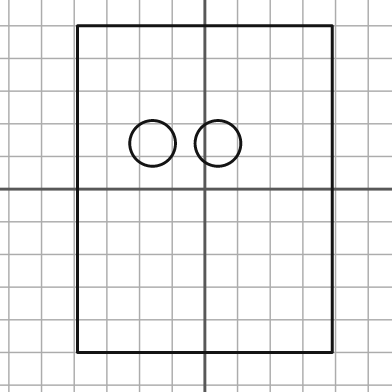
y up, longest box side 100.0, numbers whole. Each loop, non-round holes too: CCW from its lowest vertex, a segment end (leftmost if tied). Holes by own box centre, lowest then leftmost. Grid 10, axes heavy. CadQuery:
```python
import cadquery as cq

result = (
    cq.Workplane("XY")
    .moveTo(-39.0, -50.0)
    .lineTo(39.0, -50.0)
    .lineTo(39.0, 50.0)
    .lineTo(-39.0, 50.0)
    .close()
    .moveTo(-16.0, 14.0)
    .circle(7.0)
    .moveTo(4.0, 14.0)
    .circle(7.0)
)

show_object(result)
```